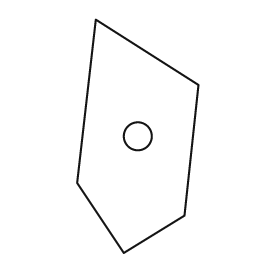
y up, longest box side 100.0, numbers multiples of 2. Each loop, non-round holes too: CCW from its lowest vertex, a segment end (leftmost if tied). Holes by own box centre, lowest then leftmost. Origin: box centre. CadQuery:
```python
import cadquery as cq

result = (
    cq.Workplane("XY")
    .moveTo(-6.0, -50.0)
    .lineTo(20.0, -34.0)
    .lineTo(26.0, 22.0)
    .lineTo(-18.0, 50.0)
    .lineTo(-26.0, -20.0)
    .close()
    .moveTo(0.0, 0.0)
    .circle(6.0)
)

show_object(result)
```